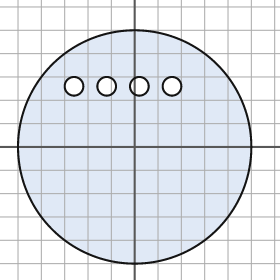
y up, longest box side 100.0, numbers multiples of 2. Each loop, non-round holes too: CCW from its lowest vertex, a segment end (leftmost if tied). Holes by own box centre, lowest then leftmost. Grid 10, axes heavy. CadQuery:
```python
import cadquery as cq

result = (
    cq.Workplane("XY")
    .moveTo(0.0, 0.0)
    .circle(50.0)
    .moveTo(-26.0, 26.0)
    .circle(4.0)
    .moveTo(-12.0, 26.0)
    .circle(4.0)
    .moveTo(2.0, 26.0)
    .circle(4.0)
    .moveTo(16.0, 26.0)
    .circle(4.0)
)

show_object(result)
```